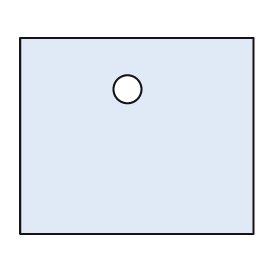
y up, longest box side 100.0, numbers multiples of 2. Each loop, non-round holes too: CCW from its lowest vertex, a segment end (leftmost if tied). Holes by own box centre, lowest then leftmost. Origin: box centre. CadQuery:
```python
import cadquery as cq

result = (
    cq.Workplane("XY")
    .moveTo(-50.0, -42.0)
    .lineTo(50.0, -42.0)
    .lineTo(50.0, 42.0)
    .lineTo(-50.0, 42.0)
    .close()
    .moveTo(-4.0, 20.0)
    .circle(6.0)
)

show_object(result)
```